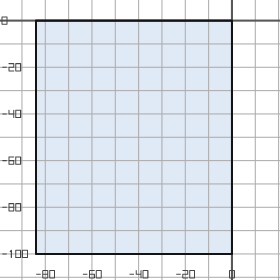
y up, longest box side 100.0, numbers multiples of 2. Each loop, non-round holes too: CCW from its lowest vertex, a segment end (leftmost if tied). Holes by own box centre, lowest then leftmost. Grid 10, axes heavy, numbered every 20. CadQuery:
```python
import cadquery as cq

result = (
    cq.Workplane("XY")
    .moveTo(-84.0, -100.0)
    .lineTo(0.0, -100.0)
    .lineTo(0.0, 0.0)
    .lineTo(-84.0, 0.0)
    .close()
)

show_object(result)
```